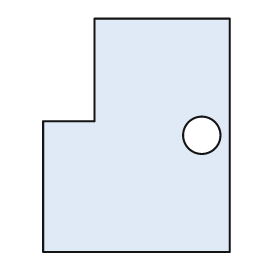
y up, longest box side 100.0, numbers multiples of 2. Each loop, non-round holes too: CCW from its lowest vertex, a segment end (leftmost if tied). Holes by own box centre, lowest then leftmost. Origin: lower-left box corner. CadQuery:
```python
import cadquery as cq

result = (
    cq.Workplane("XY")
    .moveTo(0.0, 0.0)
    .lineTo(80.0, 0.0)
    .lineTo(80.0, 100.0)
    .lineTo(22.0, 100.0)
    .lineTo(22.0, 56.0)
    .lineTo(0.0, 56.0)
    .close()
    .moveTo(68.0, 50.0)
    .circle(8.0)
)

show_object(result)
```